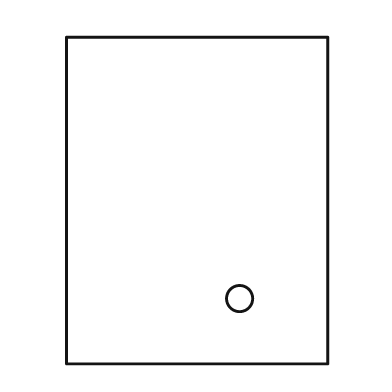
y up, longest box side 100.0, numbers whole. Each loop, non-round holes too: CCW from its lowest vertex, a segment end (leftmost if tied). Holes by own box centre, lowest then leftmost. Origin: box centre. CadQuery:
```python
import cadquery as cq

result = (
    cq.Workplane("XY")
    .moveTo(-40.0, -50.0)
    .lineTo(40.0, -50.0)
    .lineTo(40.0, 50.0)
    .lineTo(-40.0, 50.0)
    .close()
    .moveTo(13.0, -30.0)
    .circle(4.0)
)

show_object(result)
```